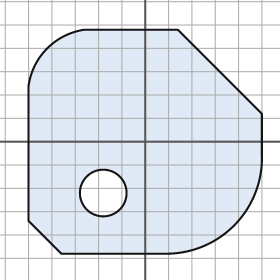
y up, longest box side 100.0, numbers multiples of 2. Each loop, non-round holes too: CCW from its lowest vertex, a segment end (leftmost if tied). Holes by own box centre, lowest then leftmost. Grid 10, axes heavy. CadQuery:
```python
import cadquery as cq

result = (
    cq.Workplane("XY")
    .moveTo(-36.0, -48.0)
    .lineTo(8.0, -48.0)
    .threePointArc((38.0, -36.0), (50.0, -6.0))
    .lineTo(50.0, 12.0)
    .lineTo(14.0, 48.0)
    .lineTo(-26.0, 48.0)
    .threePointArc((-42.0, 40.0), (-50.0, 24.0))
    .lineTo(-50.0, -34.0)
    .close()
    .moveTo(-18.0, -22.0)
    .circle(10.0)
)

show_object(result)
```